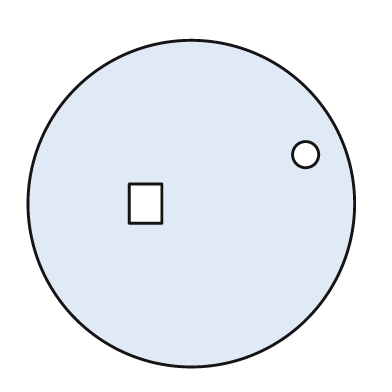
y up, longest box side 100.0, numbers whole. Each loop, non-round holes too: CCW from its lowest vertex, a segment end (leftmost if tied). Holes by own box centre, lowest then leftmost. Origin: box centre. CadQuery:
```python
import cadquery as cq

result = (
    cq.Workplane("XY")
    .moveTo(0.0, 0.0)
    .circle(50.0)
    .moveTo(-19.0, -6.0)
    .lineTo(-9.0, -6.0)
    .lineTo(-9.0, 6.0)
    .lineTo(-19.0, 6.0)
    .close()
    .moveTo(35.0, 15.0)
    .circle(4.0)
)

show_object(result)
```